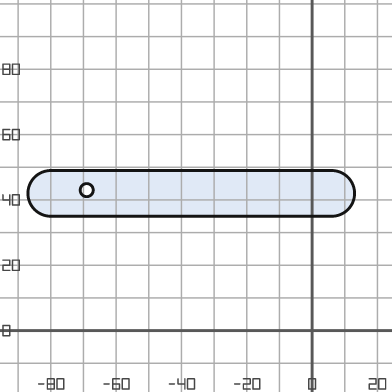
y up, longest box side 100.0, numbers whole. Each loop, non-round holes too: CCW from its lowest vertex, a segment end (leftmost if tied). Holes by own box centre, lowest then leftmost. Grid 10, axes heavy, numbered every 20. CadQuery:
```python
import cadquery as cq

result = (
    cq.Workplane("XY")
    .moveTo(-80.0, 35.0)
    .lineTo(6.0, 35.0)
    .threePointArc((13.0, 42.0), (6.0, 49.0))
    .lineTo(-80.0, 49.0)
    .threePointArc((-87.0, 42.0), (-80.0, 35.0))
    .close()
    .moveTo(-69.0, 43.0)
    .circle(2.0)
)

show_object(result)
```